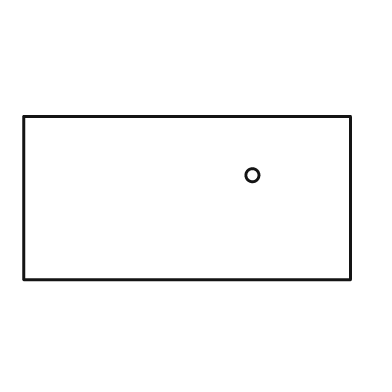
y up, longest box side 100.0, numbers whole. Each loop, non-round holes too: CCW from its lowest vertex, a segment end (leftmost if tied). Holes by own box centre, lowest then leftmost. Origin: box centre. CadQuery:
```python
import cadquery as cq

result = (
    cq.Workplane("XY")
    .moveTo(-50.0, -25.0)
    .lineTo(50.0, -25.0)
    .lineTo(50.0, 25.0)
    .lineTo(-50.0, 25.0)
    .close()
    .moveTo(20.0, 7.0)
    .circle(2.0)
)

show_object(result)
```